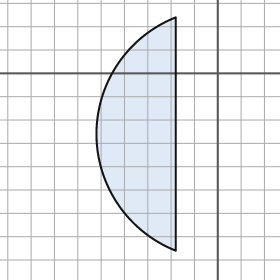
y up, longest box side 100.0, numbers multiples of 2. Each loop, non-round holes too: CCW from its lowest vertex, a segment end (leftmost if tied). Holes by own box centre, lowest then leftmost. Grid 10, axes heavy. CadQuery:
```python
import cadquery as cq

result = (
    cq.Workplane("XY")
    .moveTo(-18.0, -76.0)
    .lineTo(-18.0, 24.0)
    .threePointArc((-52.0, -26.0), (-18.0, -76.0))
    .close()
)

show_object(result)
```